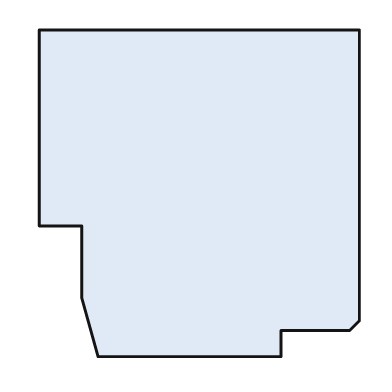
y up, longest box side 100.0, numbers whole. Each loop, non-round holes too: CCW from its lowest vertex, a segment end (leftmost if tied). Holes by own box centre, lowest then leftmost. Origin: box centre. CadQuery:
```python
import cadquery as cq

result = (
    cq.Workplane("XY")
    .moveTo(-31.0, -50.0)
    .lineTo(25.0, -50.0)
    .lineTo(25.0, -42.0)
    .lineTo(46.0, -42.0)
    .lineTo(49.0, -39.0)
    .lineTo(49.0, 50.0)
    .lineTo(-49.0, 50.0)
    .lineTo(-49.0, -10.0)
    .lineTo(-36.0, -10.0)
    .lineTo(-36.0, -32.0)
    .close()
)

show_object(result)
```